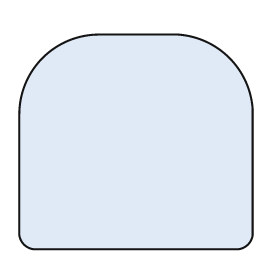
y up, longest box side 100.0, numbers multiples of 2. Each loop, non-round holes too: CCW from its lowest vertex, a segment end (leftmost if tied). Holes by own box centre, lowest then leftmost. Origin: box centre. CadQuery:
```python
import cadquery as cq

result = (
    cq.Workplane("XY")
    .moveTo(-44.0, -46.0)
    .lineTo(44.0, -46.0)
    .threePointArc((48.0, -44.0), (50.0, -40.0))
    .lineTo(50.0, 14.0)
    .threePointArc((40.0, 36.0), (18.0, 46.0))
    .lineTo(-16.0, 46.0)
    .threePointArc((-40.0, 36.0), (-50.0, 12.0))
    .lineTo(-50.0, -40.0)
    .threePointArc((-48.0, -44.0), (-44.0, -46.0))
    .close()
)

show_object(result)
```